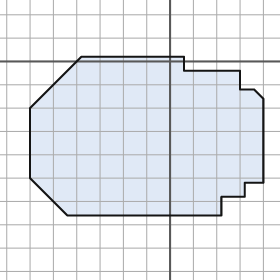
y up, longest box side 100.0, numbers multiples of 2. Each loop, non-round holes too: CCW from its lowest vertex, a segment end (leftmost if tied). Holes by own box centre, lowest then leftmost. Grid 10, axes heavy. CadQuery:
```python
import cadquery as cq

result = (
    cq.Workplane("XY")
    .moveTo(-44.0, -66.0)
    .lineTo(22.0, -66.0)
    .lineTo(22.0, -58.0)
    .lineTo(32.0, -58.0)
    .lineTo(32.0, -52.0)
    .lineTo(40.0, -52.0)
    .lineTo(40.0, -16.0)
    .lineTo(36.0, -12.0)
    .lineTo(30.0, -12.0)
    .lineTo(30.0, -4.0)
    .lineTo(6.0, -4.0)
    .lineTo(6.0, 2.0)
    .lineTo(-38.0, 2.0)
    .lineTo(-60.0, -20.0)
    .lineTo(-60.0, -50.0)
    .close()
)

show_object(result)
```